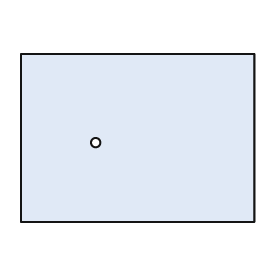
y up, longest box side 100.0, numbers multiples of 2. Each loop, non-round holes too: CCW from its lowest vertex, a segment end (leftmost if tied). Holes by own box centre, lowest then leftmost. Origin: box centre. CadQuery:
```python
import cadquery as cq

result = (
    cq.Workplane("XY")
    .moveTo(-50.0, -36.0)
    .lineTo(50.0, -36.0)
    .lineTo(50.0, 36.0)
    .lineTo(-50.0, 36.0)
    .close()
    .moveTo(-18.0, -2.0)
    .circle(2.0)
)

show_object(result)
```